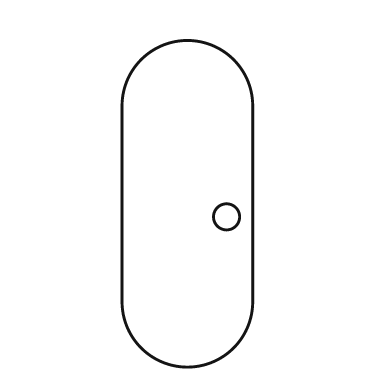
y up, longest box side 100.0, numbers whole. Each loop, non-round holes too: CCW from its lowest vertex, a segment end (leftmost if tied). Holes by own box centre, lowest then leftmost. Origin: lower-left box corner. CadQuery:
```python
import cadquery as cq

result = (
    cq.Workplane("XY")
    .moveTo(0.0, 20.0)
    .threePointArc((20.0, 0.0), (40.0, 20.0))
    .lineTo(40.0, 80.0)
    .threePointArc((20.0, 100.0), (0.0, 80.0))
    .close()
    .moveTo(32.0, 46.0)
    .circle(4.0)
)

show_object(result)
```